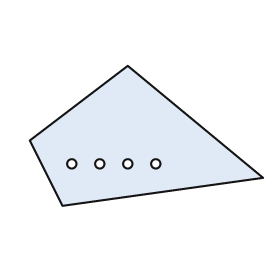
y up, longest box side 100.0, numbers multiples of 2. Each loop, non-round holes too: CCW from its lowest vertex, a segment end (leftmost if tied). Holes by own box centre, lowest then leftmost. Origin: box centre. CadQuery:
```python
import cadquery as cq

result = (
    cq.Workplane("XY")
    .moveTo(-36.0, -30.0)
    .lineTo(50.0, -18.0)
    .lineTo(-8.0, 30.0)
    .lineTo(-50.0, -2.0)
    .close()
    .moveTo(-32.0, -12.0)
    .circle(2.0)
    .moveTo(-20.0, -12.0)
    .circle(2.0)
    .moveTo(-8.0, -12.0)
    .circle(2.0)
    .moveTo(4.0, -12.0)
    .circle(2.0)
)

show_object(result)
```